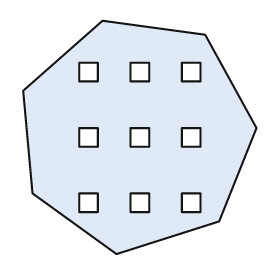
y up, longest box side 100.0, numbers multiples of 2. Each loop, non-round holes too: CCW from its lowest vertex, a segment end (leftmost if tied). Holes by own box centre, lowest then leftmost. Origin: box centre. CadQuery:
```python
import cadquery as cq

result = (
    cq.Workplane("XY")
    .moveTo(-10.0, -50.0)
    .lineTo(34.0, -36.0)
    .lineTo(50.0, 4.0)
    .lineTo(28.0, 44.0)
    .lineTo(-16.0, 50.0)
    .lineTo(-50.0, 20.0)
    .lineTo(-46.0, -24.0)
    .close()
    .moveTo(-26.0, -32.0)
    .lineTo(-18.0, -32.0)
    .lineTo(-18.0, -24.0)
    .lineTo(-26.0, -24.0)
    .close()
    .moveTo(-4.0, -32.0)
    .lineTo(4.0, -32.0)
    .lineTo(4.0, -24.0)
    .lineTo(-4.0, -24.0)
    .close()
    .moveTo(18.0, -32.0)
    .lineTo(26.0, -32.0)
    .lineTo(26.0, -24.0)
    .lineTo(18.0, -24.0)
    .close()
    .moveTo(-26.0, -4.0)
    .lineTo(-18.0, -4.0)
    .lineTo(-18.0, 4.0)
    .lineTo(-26.0, 4.0)
    .close()
    .moveTo(-4.0, -4.0)
    .lineTo(4.0, -4.0)
    .lineTo(4.0, 4.0)
    .lineTo(-4.0, 4.0)
    .close()
    .moveTo(18.0, -4.0)
    .lineTo(26.0, -4.0)
    .lineTo(26.0, 4.0)
    .lineTo(18.0, 4.0)
    .close()
    .moveTo(-26.0, 24.0)
    .lineTo(-18.0, 24.0)
    .lineTo(-18.0, 32.0)
    .lineTo(-26.0, 32.0)
    .close()
    .moveTo(-4.0, 24.0)
    .lineTo(4.0, 24.0)
    .lineTo(4.0, 32.0)
    .lineTo(-4.0, 32.0)
    .close()
    .moveTo(18.0, 24.0)
    .lineTo(26.0, 24.0)
    .lineTo(26.0, 32.0)
    .lineTo(18.0, 32.0)
    .close()
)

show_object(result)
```